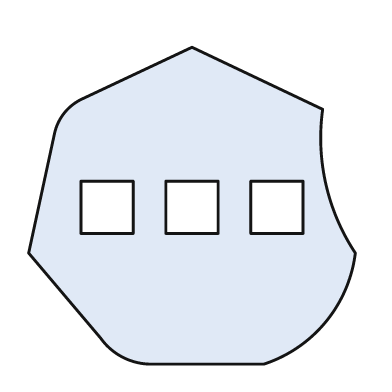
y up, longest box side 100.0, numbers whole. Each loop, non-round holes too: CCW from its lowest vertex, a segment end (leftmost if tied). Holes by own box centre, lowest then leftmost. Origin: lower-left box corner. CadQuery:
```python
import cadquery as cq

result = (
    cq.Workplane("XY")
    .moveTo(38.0, 0.0)
    .lineTo(72.0, 0.0)
    .threePointArc((91.0, 13.0), (100.0, 34.0))
    .threePointArc((91.0, 55.0), (90.0, 78.0))
    .lineTo(50.0, 97.0)
    .lineTo(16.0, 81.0)
    .threePointArc((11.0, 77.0), (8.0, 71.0))
    .lineTo(0.0, 34.0)
    .lineTo(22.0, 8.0)
    .threePointArc((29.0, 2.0), (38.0, 0.0))
    .close()
    .moveTo(16.0, 40.0)
    .lineTo(32.0, 40.0)
    .lineTo(32.0, 56.0)
    .lineTo(16.0, 56.0)
    .close()
    .moveTo(42.0, 40.0)
    .lineTo(58.0, 40.0)
    .lineTo(58.0, 56.0)
    .lineTo(42.0, 56.0)
    .close()
    .moveTo(68.0, 40.0)
    .lineTo(84.0, 40.0)
    .lineTo(84.0, 56.0)
    .lineTo(68.0, 56.0)
    .close()
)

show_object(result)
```